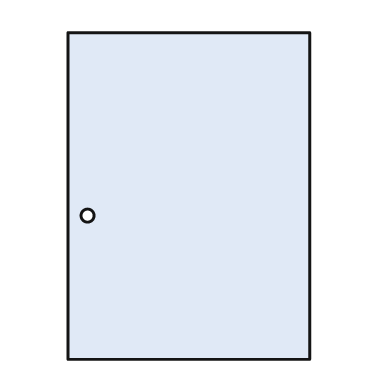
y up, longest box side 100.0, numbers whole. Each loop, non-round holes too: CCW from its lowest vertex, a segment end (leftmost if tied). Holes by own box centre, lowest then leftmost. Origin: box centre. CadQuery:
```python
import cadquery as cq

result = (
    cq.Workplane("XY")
    .moveTo(-37.0, -50.0)
    .lineTo(37.0, -50.0)
    .lineTo(37.0, 50.0)
    .lineTo(-37.0, 50.0)
    .close()
    .moveTo(-31.0, -6.0)
    .circle(2.0)
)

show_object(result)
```